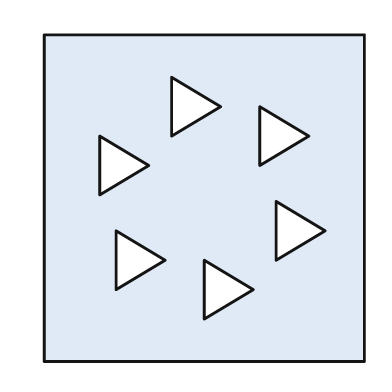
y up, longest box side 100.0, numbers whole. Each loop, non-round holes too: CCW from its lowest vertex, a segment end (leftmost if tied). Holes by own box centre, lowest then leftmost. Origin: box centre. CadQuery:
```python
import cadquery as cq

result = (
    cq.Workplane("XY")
    .moveTo(-49.0, -50.0)
    .lineTo(49.0, -50.0)
    .lineTo(49.0, 50.0)
    .lineTo(-49.0, 50.0)
    .close()
    .moveTo(0.0, -37.0)
    .lineTo(15.0, -28.0)
    .lineTo(0.0, -19.0)
    .close()
    .moveTo(-27.0, -28.0)
    .lineTo(-12.0, -19.0)
    .lineTo(-27.0, -10.0)
    .close()
    .moveTo(22.0, -19.0)
    .lineTo(37.0, -10.0)
    .lineTo(22.0, -1.0)
    .close()
    .moveTo(-32.0, 1.0)
    .lineTo(-17.0, 10.0)
    .lineTo(-32.0, 19.0)
    .close()
    .moveTo(17.0, 10.0)
    .lineTo(32.0, 19.0)
    .lineTo(17.0, 28.0)
    .close()
    .moveTo(-10.0, 19.0)
    .lineTo(5.0, 28.0)
    .lineTo(-10.0, 37.0)
    .close()
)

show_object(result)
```